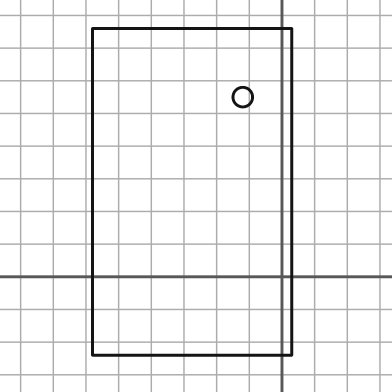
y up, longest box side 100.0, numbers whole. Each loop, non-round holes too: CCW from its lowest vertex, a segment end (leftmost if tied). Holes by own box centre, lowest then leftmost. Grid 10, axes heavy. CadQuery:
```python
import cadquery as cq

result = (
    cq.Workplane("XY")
    .moveTo(-58.0, -24.0)
    .lineTo(3.0, -24.0)
    .lineTo(3.0, 76.0)
    .lineTo(-58.0, 76.0)
    .close()
    .moveTo(-12.0, 55.0)
    .circle(3.0)
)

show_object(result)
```